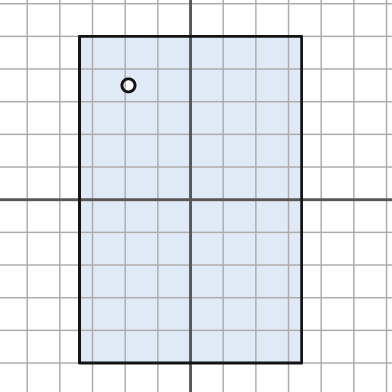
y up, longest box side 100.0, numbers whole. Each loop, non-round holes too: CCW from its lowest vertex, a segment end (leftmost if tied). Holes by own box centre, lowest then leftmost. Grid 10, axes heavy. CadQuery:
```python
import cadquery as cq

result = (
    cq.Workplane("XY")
    .moveTo(-34.0, -50.0)
    .lineTo(34.0, -50.0)
    .lineTo(34.0, 50.0)
    .lineTo(-34.0, 50.0)
    .close()
    .moveTo(-19.0, 35.0)
    .circle(2.0)
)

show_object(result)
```